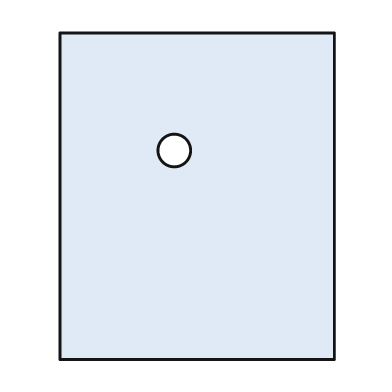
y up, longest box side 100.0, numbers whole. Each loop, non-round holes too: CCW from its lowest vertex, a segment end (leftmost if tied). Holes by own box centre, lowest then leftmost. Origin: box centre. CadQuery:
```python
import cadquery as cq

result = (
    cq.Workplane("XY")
    .moveTo(-42.0, -50.0)
    .lineTo(42.0, -50.0)
    .lineTo(42.0, 50.0)
    .lineTo(-42.0, 50.0)
    .close()
    .moveTo(-7.0, 14.0)
    .circle(5.0)
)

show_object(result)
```